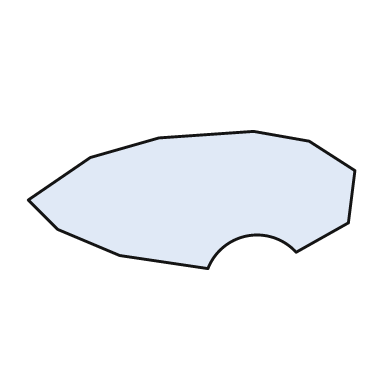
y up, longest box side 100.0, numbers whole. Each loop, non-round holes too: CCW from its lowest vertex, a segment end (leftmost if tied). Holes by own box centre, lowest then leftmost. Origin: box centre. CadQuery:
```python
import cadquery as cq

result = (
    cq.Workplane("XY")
    .moveTo(5.0, -21.0)
    .threePointArc((17.0, -11.0), (32.0, -16.0))
    .lineTo(48.0, -7.0)
    .lineTo(50.0, 9.0)
    .lineTo(36.0, 18.0)
    .lineTo(19.0, 21.0)
    .lineTo(-10.0, 19.0)
    .lineTo(-31.0, 13.0)
    .lineTo(-50.0, 0.0)
    .lineTo(-41.0, -9.0)
    .lineTo(-22.0, -17.0)
    .close()
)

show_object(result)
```